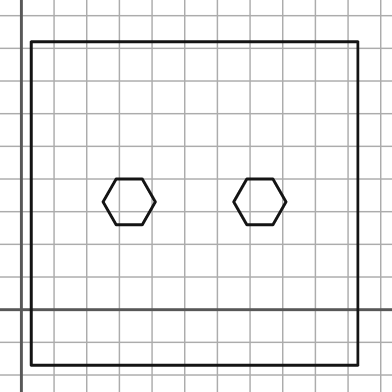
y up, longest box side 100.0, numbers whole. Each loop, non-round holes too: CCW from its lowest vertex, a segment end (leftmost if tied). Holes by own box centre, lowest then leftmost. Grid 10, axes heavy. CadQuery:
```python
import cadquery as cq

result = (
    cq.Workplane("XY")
    .moveTo(3.0, -17.0)
    .lineTo(103.0, -17.0)
    .lineTo(103.0, 82.0)
    .lineTo(3.0, 82.0)
    .close()
    .moveTo(29.0, 26.0)
    .lineTo(37.0, 26.0)
    .lineTo(41.0, 33.0)
    .lineTo(37.0, 40.0)
    .lineTo(29.0, 40.0)
    .lineTo(25.0, 33.0)
    .close()
    .moveTo(69.0, 26.0)
    .lineTo(77.0, 26.0)
    .lineTo(81.0, 33.0)
    .lineTo(77.0, 40.0)
    .lineTo(69.0, 40.0)
    .lineTo(65.0, 33.0)
    .close()
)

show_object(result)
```